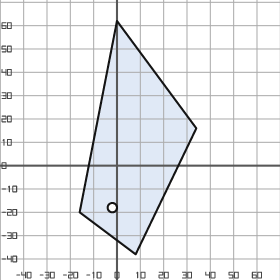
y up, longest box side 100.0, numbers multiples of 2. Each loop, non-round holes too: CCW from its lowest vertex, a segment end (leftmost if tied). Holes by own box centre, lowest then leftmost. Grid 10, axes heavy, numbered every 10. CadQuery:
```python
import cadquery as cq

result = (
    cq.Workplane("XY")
    .moveTo(8.0, -38.0)
    .lineTo(34.0, 16.0)
    .lineTo(0.0, 62.0)
    .lineTo(-16.0, -20.0)
    .close()
    .moveTo(-2.0, -18.0)
    .circle(2.0)
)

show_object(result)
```